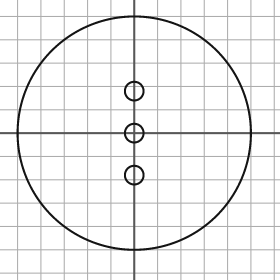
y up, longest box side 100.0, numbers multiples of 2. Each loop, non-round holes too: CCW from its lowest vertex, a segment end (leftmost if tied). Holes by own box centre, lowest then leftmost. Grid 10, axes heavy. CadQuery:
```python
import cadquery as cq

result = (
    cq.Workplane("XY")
    .moveTo(0.0, 0.0)
    .circle(50.0)
    .moveTo(0.0, -18.0)
    .circle(4.0)
    .moveTo(0.0, 0.0)
    .circle(4.0)
    .moveTo(0.0, 18.0)
    .circle(4.0)
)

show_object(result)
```